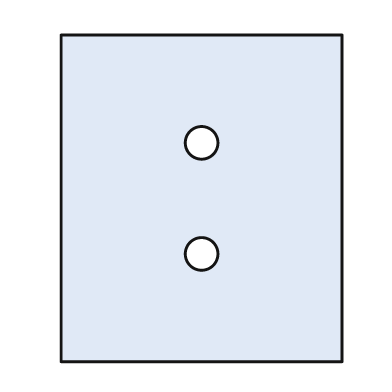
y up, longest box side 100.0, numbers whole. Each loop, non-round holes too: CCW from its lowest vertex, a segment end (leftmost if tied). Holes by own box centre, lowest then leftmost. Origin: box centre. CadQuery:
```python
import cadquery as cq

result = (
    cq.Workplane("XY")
    .moveTo(-43.0, -50.0)
    .lineTo(43.0, -50.0)
    .lineTo(43.0, 50.0)
    .lineTo(-43.0, 50.0)
    .close()
    .moveTo(0.0, -17.0)
    .circle(5.0)
    .moveTo(0.0, 17.0)
    .circle(5.0)
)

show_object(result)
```